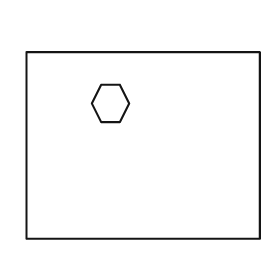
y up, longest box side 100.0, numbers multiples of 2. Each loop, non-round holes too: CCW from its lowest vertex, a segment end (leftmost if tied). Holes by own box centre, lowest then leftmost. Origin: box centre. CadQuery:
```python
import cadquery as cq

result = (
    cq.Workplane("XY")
    .moveTo(-50.0, -40.0)
    .lineTo(50.0, -40.0)
    .lineTo(50.0, 40.0)
    .lineTo(-50.0, 40.0)
    .close()
    .moveTo(-18.0, 10.0)
    .lineTo(-10.0, 10.0)
    .lineTo(-6.0, 18.0)
    .lineTo(-10.0, 26.0)
    .lineTo(-18.0, 26.0)
    .lineTo(-22.0, 18.0)
    .close()
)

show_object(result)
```